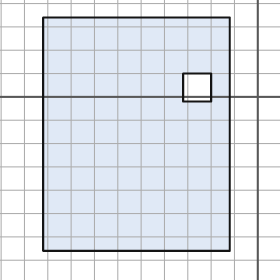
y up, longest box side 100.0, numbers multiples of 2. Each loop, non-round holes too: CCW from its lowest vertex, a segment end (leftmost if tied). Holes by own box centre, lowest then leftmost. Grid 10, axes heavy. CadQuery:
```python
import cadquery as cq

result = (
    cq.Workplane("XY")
    .moveTo(-92.0, -66.0)
    .lineTo(-12.0, -66.0)
    .lineTo(-12.0, 34.0)
    .lineTo(-92.0, 34.0)
    .close()
    .moveTo(-32.0, -2.0)
    .lineTo(-20.0, -2.0)
    .lineTo(-20.0, 10.0)
    .lineTo(-32.0, 10.0)
    .close()
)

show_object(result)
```